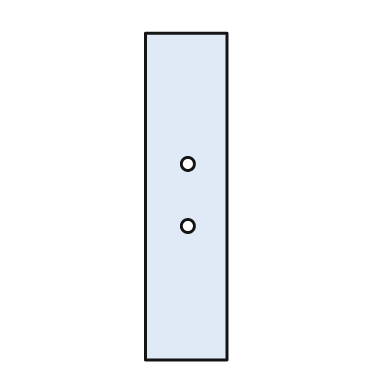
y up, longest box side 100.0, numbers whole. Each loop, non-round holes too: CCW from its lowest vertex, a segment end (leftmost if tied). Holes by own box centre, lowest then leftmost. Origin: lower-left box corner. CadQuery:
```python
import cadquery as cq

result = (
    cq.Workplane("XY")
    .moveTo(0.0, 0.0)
    .lineTo(25.0, 0.0)
    .lineTo(25.0, 100.0)
    .lineTo(0.0, 100.0)
    .close()
    .moveTo(13.0, 41.0)
    .circle(2.0)
    .moveTo(13.0, 60.0)
    .circle(2.0)
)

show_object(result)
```